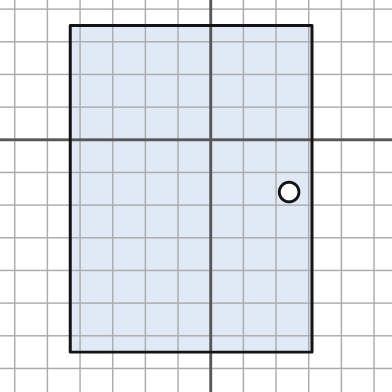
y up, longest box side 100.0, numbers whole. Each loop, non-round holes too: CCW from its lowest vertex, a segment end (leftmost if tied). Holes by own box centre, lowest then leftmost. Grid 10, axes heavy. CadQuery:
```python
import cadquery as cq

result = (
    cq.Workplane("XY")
    .moveTo(-43.0, -65.0)
    .lineTo(31.0, -65.0)
    .lineTo(31.0, 35.0)
    .lineTo(-43.0, 35.0)
    .close()
    .moveTo(24.0, -16.0)
    .circle(3.0)
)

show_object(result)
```